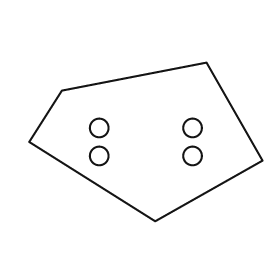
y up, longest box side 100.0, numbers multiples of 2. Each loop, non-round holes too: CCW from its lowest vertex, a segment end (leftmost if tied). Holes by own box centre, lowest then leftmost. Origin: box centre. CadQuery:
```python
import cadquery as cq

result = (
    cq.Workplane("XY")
    .moveTo(4.0, -34.0)
    .lineTo(50.0, -8.0)
    .lineTo(26.0, 34.0)
    .lineTo(-36.0, 22.0)
    .lineTo(-50.0, 0.0)
    .close()
    .moveTo(-20.0, -6.0)
    .circle(4.0)
    .moveTo(20.0, -6.0)
    .circle(4.0)
    .moveTo(-20.0, 6.0)
    .circle(4.0)
    .moveTo(20.0, 6.0)
    .circle(4.0)
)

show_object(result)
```